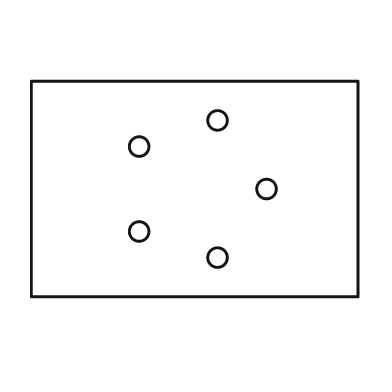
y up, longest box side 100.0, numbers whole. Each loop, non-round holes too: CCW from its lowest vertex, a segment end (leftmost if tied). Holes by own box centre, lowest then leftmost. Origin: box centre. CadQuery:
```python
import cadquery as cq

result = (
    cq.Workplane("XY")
    .moveTo(-50.0, -33.0)
    .lineTo(50.0, -33.0)
    .lineTo(50.0, 33.0)
    .lineTo(-50.0, 33.0)
    .close()
    .moveTo(7.0, -21.0)
    .circle(3.0)
    .moveTo(-17.0, -13.0)
    .circle(3.0)
    .moveTo(22.0, 0.0)
    .circle(3.0)
    .moveTo(-17.0, 13.0)
    .circle(3.0)
    .moveTo(7.0, 21.0)
    .circle(3.0)
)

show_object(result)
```